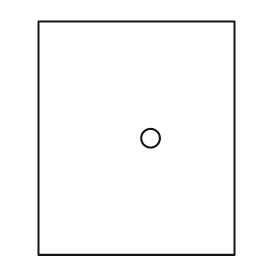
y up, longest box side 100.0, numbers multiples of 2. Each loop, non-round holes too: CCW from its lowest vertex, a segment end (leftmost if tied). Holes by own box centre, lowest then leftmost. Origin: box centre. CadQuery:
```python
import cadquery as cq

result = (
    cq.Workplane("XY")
    .moveTo(-42.0, -50.0)
    .lineTo(42.0, -50.0)
    .lineTo(42.0, 50.0)
    .lineTo(-42.0, 50.0)
    .close()
    .moveTo(6.0, 0.0)
    .circle(4.0)
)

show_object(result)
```